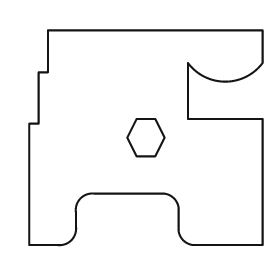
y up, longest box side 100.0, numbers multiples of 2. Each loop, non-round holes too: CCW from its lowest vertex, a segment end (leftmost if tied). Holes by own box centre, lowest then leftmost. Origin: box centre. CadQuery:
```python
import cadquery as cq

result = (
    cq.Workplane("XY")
    .moveTo(-50.0, -46.0)
    .lineTo(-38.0, -46.0)
    .threePointArc((-32.0, -44.0), (-30.0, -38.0))
    .lineTo(-30.0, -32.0)
    .threePointArc((-28.0, -26.0), (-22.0, -24.0))
    .lineTo(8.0, -24.0)
    .threePointArc((12.0, -26.0), (14.0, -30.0))
    .lineTo(14.0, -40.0)
    .threePointArc((16.0, -44.0), (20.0, -46.0))
    .lineTo(50.0, -46.0)
    .lineTo(50.0, 8.0)
    .lineTo(18.0, 8.0)
    .lineTo(18.0, 32.0)
    .threePointArc((34.0, 24.0), (50.0, 32.0))
    .lineTo(50.0, 46.0)
    .lineTo(-42.0, 46.0)
    .lineTo(-42.0, 28.0)
    .lineTo(-46.0, 28.0)
    .lineTo(-46.0, 6.0)
    .lineTo(-50.0, 6.0)
    .close()
    .moveTo(-4.0, -8.0)
    .lineTo(4.0, -8.0)
    .lineTo(8.0, 0.0)
    .lineTo(4.0, 8.0)
    .lineTo(-4.0, 8.0)
    .lineTo(-8.0, 0.0)
    .close()
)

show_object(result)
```